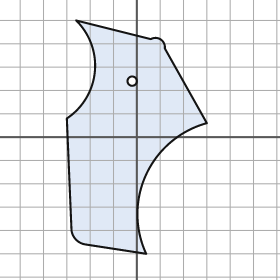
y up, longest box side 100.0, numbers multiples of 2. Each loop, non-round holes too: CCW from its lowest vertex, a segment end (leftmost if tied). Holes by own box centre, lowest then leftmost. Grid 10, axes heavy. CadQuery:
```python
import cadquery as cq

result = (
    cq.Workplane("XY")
    .moveTo(4.0, -50.0)
    .threePointArc((4.0, -16.0), (30.0, 6.0))
    .lineTo(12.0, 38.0)
    .threePointArc((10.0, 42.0), (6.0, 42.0))
    .lineTo(-26.0, 50.0)
    .threePointArc((-18.0, 28.0), (-30.0, 8.0))
    .lineTo(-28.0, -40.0)
    .threePointArc((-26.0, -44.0), (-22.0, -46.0))
    .close()
    .moveTo(-2.0, 24.0)
    .circle(2.0)
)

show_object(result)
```